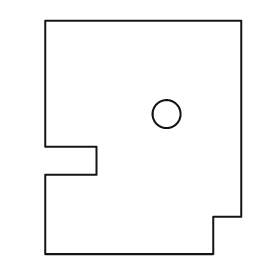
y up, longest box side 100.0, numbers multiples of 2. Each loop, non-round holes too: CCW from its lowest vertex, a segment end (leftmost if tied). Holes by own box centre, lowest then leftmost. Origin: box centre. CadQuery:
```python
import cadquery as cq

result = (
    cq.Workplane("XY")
    .moveTo(-42.0, -50.0)
    .lineTo(30.0, -50.0)
    .lineTo(30.0, -34.0)
    .lineTo(42.0, -34.0)
    .lineTo(42.0, 50.0)
    .lineTo(-42.0, 50.0)
    .lineTo(-42.0, -4.0)
    .lineTo(-20.0, -4.0)
    .lineTo(-20.0, -16.0)
    .lineTo(-42.0, -16.0)
    .close()
    .moveTo(10.0, 10.0)
    .circle(6.0)
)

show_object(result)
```